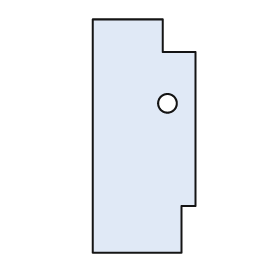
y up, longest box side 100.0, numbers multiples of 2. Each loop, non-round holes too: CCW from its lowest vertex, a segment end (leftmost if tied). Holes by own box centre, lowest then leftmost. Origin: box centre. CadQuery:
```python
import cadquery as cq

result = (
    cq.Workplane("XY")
    .moveTo(-22.0, -50.0)
    .lineTo(16.0, -50.0)
    .lineTo(16.0, -30.0)
    .lineTo(22.0, -30.0)
    .lineTo(22.0, 36.0)
    .lineTo(8.0, 36.0)
    .lineTo(8.0, 50.0)
    .lineTo(-22.0, 50.0)
    .close()
    .moveTo(10.0, 14.0)
    .circle(4.0)
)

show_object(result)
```